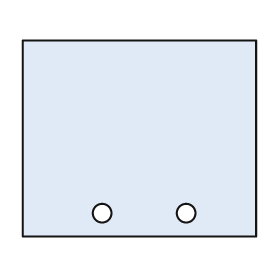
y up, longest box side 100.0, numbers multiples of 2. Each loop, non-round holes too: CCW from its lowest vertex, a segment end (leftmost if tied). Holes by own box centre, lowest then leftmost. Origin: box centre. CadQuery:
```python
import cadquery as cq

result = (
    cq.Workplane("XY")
    .moveTo(-50.0, -42.0)
    .lineTo(50.0, -42.0)
    .lineTo(50.0, 42.0)
    .lineTo(-50.0, 42.0)
    .close()
    .moveTo(-16.0, -32.0)
    .circle(4.0)
    .moveTo(20.0, -32.0)
    .circle(4.0)
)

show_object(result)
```